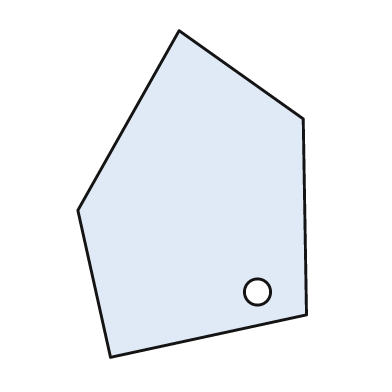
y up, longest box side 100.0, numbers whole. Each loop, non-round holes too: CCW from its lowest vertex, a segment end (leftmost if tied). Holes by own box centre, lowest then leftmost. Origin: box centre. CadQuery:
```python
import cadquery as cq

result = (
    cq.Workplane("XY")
    .moveTo(-25.0, -50.0)
    .lineTo(35.0, -37.0)
    .lineTo(34.0, 23.0)
    .lineTo(-4.0, 50.0)
    .lineTo(-35.0, -5.0)
    .close()
    .moveTo(20.0, -30.0)
    .circle(4.0)
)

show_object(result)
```